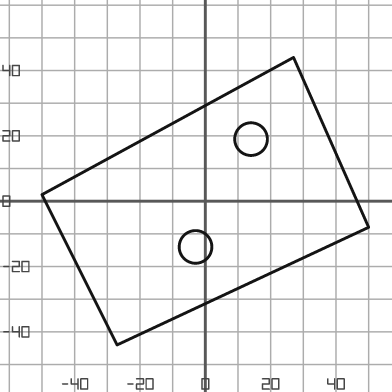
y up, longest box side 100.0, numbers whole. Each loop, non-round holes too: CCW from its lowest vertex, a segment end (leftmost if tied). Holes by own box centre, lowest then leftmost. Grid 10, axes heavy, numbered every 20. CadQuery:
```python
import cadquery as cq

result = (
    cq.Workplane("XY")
    .moveTo(-27.0, -44.0)
    .lineTo(50.0, -8.0)
    .lineTo(27.0, 44.0)
    .lineTo(-50.0, 2.0)
    .close()
    .moveTo(-3.0, -14.0)
    .circle(5.0)
    .moveTo(14.0, 19.0)
    .circle(5.0)
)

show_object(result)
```